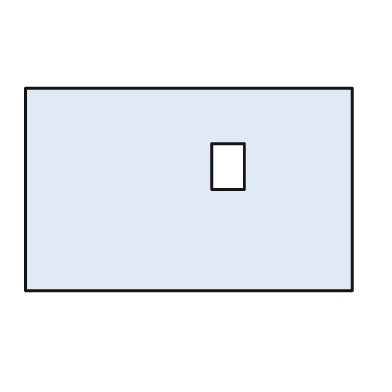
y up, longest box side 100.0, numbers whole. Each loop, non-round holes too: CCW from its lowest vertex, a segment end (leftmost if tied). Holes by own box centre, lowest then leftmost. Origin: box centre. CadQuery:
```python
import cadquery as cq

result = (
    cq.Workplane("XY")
    .moveTo(-50.0, -31.0)
    .lineTo(50.0, -31.0)
    .lineTo(50.0, 31.0)
    .lineTo(-50.0, 31.0)
    .close()
    .moveTo(7.0, 0.0)
    .lineTo(17.0, 0.0)
    .lineTo(17.0, 14.0)
    .lineTo(7.0, 14.0)
    .close()
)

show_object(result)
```